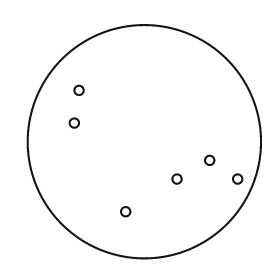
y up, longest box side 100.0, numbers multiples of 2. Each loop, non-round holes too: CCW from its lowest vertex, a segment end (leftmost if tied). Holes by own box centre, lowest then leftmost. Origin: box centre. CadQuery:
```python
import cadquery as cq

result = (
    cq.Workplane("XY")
    .moveTo(0.0, 0.0)
    .circle(50.0)
    .moveTo(-8.0, -30.0)
    .circle(2.0)
    .moveTo(14.0, -16.0)
    .circle(2.0)
    .moveTo(40.0, -16.0)
    .circle(2.0)
    .moveTo(28.0, -8.0)
    .circle(2.0)
    .moveTo(-30.0, 8.0)
    .circle(2.0)
    .moveTo(-28.0, 22.0)
    .circle(2.0)
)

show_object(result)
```